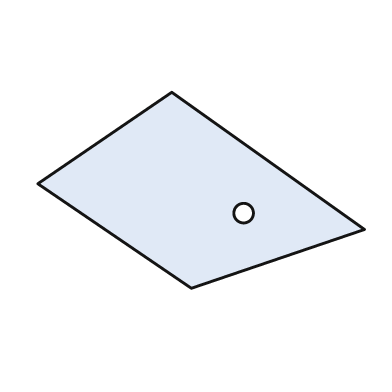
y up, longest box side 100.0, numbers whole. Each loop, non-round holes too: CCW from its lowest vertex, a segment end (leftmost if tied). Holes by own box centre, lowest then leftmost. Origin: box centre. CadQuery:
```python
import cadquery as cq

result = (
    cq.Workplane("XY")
    .moveTo(-3.0, -30.0)
    .lineTo(50.0, -12.0)
    .lineTo(-9.0, 30.0)
    .lineTo(-50.0, 2.0)
    .close()
    .moveTo(13.0, -7.0)
    .circle(3.0)
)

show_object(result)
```